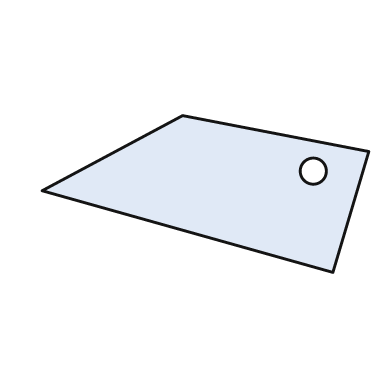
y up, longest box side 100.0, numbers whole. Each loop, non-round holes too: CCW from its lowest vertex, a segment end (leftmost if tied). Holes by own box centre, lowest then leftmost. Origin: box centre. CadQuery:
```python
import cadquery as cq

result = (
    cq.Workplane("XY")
    .moveTo(39.0, -24.0)
    .lineTo(50.0, 13.0)
    .lineTo(-7.0, 24.0)
    .lineTo(-50.0, 1.0)
    .close()
    .moveTo(33.0, 7.0)
    .circle(4.0)
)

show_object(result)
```